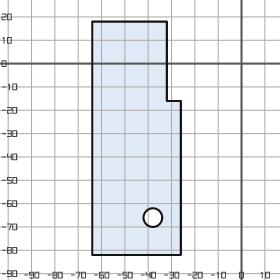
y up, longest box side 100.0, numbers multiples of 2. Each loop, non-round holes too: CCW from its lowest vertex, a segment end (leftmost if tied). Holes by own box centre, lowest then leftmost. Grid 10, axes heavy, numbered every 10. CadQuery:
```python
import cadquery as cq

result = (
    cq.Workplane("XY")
    .moveTo(-64.0, -82.0)
    .lineTo(-26.0, -82.0)
    .lineTo(-26.0, -16.0)
    .lineTo(-32.0, -16.0)
    .lineTo(-32.0, 18.0)
    .lineTo(-64.0, 18.0)
    .close()
    .moveTo(-38.0, -66.0)
    .circle(4.0)
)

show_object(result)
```